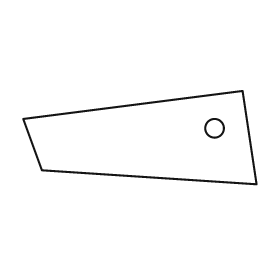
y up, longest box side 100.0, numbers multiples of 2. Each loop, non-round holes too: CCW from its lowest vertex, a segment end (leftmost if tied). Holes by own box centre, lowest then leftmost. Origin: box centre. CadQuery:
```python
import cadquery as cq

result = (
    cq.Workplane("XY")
    .moveTo(50.0, -20.0)
    .lineTo(44.0, 20.0)
    .lineTo(-50.0, 8.0)
    .lineTo(-42.0, -14.0)
    .close()
    .moveTo(32.0, 4.0)
    .circle(4.0)
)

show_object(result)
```